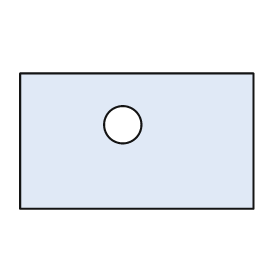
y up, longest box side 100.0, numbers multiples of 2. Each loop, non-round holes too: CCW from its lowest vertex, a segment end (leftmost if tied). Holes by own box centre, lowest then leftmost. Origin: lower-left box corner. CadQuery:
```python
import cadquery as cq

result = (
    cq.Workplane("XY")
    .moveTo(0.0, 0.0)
    .lineTo(100.0, 0.0)
    .lineTo(100.0, 58.0)
    .lineTo(0.0, 58.0)
    .close()
    .moveTo(44.0, 36.0)
    .circle(8.0)
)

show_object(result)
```